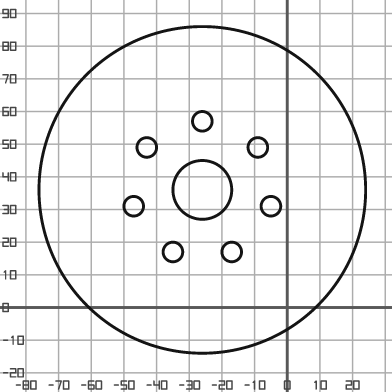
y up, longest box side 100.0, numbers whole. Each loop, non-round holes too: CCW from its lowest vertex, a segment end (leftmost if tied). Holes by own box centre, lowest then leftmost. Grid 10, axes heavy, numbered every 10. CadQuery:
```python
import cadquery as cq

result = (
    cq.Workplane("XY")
    .moveTo(-26.0, 36.0)
    .circle(50.0)
    .moveTo(-35.0, 17.0)
    .circle(3.0)
    .moveTo(-17.0, 17.0)
    .circle(3.0)
    .moveTo(-47.0, 31.0)
    .circle(3.0)
    .moveTo(-5.0, 31.0)
    .circle(3.0)
    .moveTo(-26.0, 36.0)
    .circle(9.0)
    .moveTo(-43.0, 49.0)
    .circle(3.0)
    .moveTo(-9.0, 49.0)
    .circle(3.0)
    .moveTo(-26.0, 57.0)
    .circle(3.0)
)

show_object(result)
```